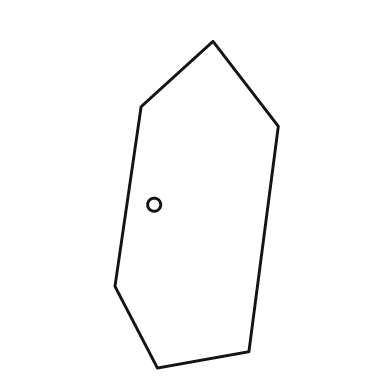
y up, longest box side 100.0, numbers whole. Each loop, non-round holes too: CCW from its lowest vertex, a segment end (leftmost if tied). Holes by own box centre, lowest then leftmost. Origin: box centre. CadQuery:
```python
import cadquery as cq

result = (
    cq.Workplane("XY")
    .moveTo(-12.0, -50.0)
    .lineTo(16.0, -45.0)
    .lineTo(25.0, 24.0)
    .lineTo(5.0, 50.0)
    .lineTo(-17.0, 30.0)
    .lineTo(-25.0, -25.0)
    .close()
    .moveTo(-13.0, 0.0)
    .circle(2.0)
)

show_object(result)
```